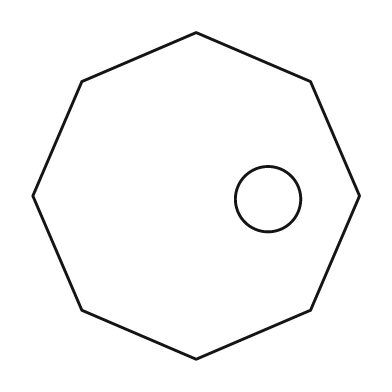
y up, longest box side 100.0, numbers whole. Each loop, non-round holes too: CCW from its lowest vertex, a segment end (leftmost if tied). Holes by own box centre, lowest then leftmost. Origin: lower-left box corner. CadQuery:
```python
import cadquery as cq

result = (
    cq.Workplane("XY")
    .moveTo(50.0, 0.0)
    .lineTo(85.0, 15.0)
    .lineTo(100.0, 50.0)
    .lineTo(85.0, 85.0)
    .lineTo(50.0, 100.0)
    .lineTo(15.0, 85.0)
    .lineTo(0.0, 50.0)
    .lineTo(15.0, 15.0)
    .close()
    .moveTo(72.0, 49.0)
    .circle(10.0)
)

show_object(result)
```